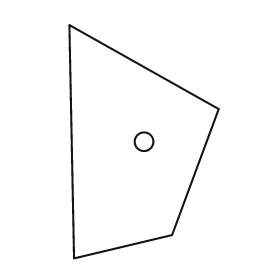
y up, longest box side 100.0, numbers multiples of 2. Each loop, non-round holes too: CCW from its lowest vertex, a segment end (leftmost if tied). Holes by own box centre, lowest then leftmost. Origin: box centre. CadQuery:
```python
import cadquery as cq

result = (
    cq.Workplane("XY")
    .moveTo(-30.0, -50.0)
    .lineTo(12.0, -40.0)
    .lineTo(32.0, 14.0)
    .lineTo(-32.0, 50.0)
    .close()
    .moveTo(0.0, 0.0)
    .circle(4.0)
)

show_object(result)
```